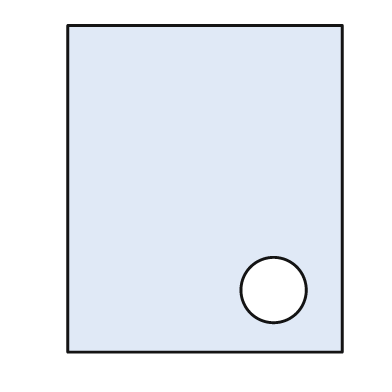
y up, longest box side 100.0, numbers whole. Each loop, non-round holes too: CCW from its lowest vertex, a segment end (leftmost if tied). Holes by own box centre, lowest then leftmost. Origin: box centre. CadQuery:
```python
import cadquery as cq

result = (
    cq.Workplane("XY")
    .moveTo(-42.0, -50.0)
    .lineTo(42.0, -50.0)
    .lineTo(42.0, 50.0)
    .lineTo(-42.0, 50.0)
    .close()
    .moveTo(21.0, -31.0)
    .circle(10.0)
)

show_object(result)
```